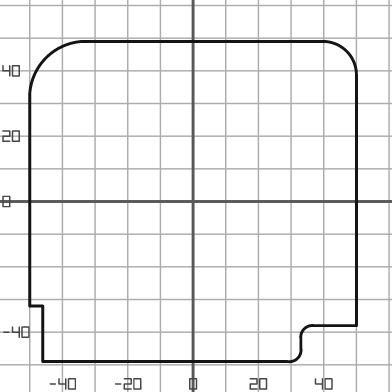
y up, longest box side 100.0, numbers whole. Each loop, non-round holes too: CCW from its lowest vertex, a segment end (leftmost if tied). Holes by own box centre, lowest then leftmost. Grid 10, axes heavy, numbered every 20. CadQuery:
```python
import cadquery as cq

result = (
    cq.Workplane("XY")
    .moveTo(-46.0, -49.0)
    .lineTo(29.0, -49.0)
    .threePointArc((32.0, -48.0), (33.0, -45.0))
    .lineTo(33.0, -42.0)
    .threePointArc((34.0, -39.0), (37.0, -38.0))
    .lineTo(50.0, -38.0)
    .lineTo(50.0, 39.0)
    .threePointArc((47.0, 46.0), (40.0, 49.0))
    .lineTo(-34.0, 49.0)
    .threePointArc((-45.0, 44.0), (-50.0, 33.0))
    .lineTo(-50.0, -32.0)
    .lineTo(-46.0, -32.0)
    .close()
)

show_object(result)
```